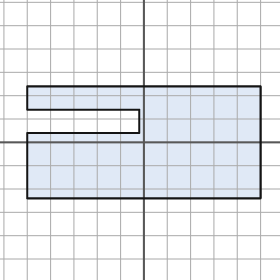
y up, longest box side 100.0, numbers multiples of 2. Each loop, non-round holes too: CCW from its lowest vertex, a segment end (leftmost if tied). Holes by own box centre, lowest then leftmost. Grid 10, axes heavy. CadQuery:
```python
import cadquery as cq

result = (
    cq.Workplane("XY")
    .moveTo(-50.0, -24.0)
    .lineTo(50.0, -24.0)
    .lineTo(50.0, 24.0)
    .lineTo(-50.0, 24.0)
    .lineTo(-50.0, 14.0)
    .lineTo(-2.0, 14.0)
    .lineTo(-2.0, 4.0)
    .lineTo(-50.0, 4.0)
    .close()
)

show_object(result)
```